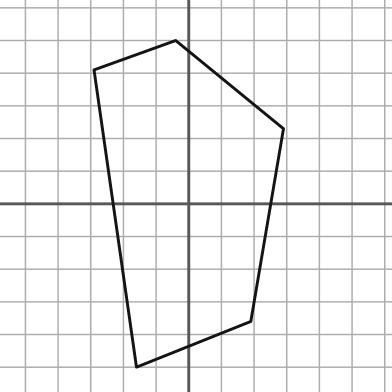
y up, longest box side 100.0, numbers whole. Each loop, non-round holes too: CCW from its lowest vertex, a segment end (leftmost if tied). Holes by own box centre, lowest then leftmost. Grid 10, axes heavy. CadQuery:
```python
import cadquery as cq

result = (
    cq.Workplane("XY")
    .moveTo(-16.0, -50.0)
    .lineTo(19.0, -36.0)
    .lineTo(29.0, 23.0)
    .lineTo(-4.0, 50.0)
    .lineTo(-29.0, 41.0)
    .close()
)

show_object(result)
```